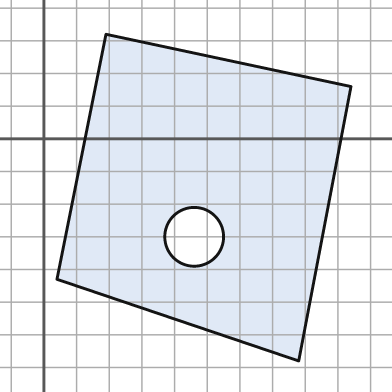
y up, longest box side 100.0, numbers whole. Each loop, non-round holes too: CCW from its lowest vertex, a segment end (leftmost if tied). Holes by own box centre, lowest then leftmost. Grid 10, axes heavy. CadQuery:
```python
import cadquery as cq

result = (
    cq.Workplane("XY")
    .moveTo(78.0, -68.0)
    .lineTo(94.0, 16.0)
    .lineTo(19.0, 32.0)
    .lineTo(4.0, -43.0)
    .close()
    .moveTo(46.0, -30.0)
    .circle(9.0)
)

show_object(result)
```